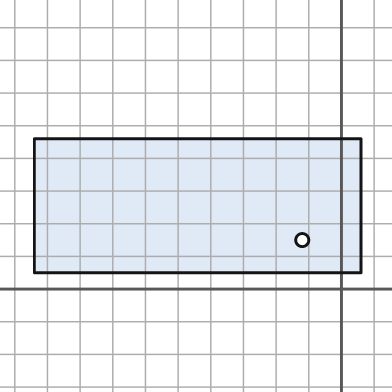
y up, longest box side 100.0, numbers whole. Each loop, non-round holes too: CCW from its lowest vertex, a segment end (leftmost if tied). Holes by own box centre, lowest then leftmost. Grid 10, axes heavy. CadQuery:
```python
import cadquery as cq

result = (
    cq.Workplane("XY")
    .moveTo(-94.0, 5.0)
    .lineTo(6.0, 5.0)
    .lineTo(6.0, 46.0)
    .lineTo(-94.0, 46.0)
    .close()
    .moveTo(-12.0, 15.0)
    .circle(2.0)
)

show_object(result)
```